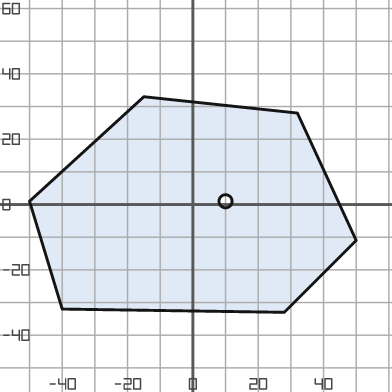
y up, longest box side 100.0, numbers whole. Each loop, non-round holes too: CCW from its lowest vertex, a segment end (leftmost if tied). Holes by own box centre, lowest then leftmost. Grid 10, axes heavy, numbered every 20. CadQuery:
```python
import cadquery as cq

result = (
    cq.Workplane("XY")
    .moveTo(28.0, -33.0)
    .lineTo(50.0, -11.0)
    .lineTo(32.0, 28.0)
    .lineTo(-15.0, 33.0)
    .lineTo(-50.0, 1.0)
    .lineTo(-40.0, -32.0)
    .close()
    .moveTo(10.0, 1.0)
    .circle(2.0)
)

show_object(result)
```